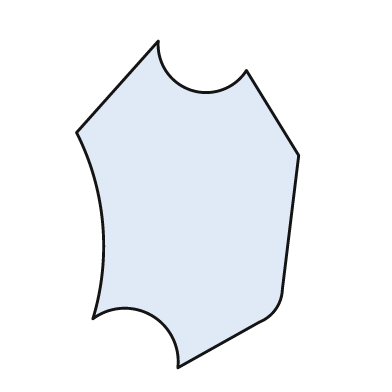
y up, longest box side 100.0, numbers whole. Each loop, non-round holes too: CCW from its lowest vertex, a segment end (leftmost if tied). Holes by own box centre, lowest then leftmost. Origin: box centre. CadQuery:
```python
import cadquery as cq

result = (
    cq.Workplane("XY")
    .moveTo(-3.0, -50.0)
    .lineTo(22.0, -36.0)
    .threePointArc((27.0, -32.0), (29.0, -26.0))
    .lineTo(34.0, 15.0)
    .lineTo(18.0, 41.0)
    .threePointArc((1.0, 35.0), (-9.0, 50.0))
    .lineTo(-34.0, 22.0)
    .threePointArc((-26.0, -6.0), (-29.0, -35.0))
    .threePointArc((-11.0, -34.0), (-3.0, -50.0))
    .close()
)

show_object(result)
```